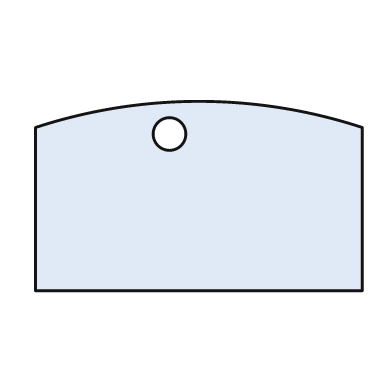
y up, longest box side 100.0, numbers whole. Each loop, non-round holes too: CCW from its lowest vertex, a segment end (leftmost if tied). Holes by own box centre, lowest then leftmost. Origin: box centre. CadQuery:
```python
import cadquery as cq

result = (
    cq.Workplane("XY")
    .moveTo(-50.0, -29.0)
    .lineTo(50.0, -29.0)
    .lineTo(50.0, 21.0)
    .threePointArc((0.0, 29.0), (-50.0, 21.0))
    .close()
    .moveTo(-9.0, 19.0)
    .circle(5.0)
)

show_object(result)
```